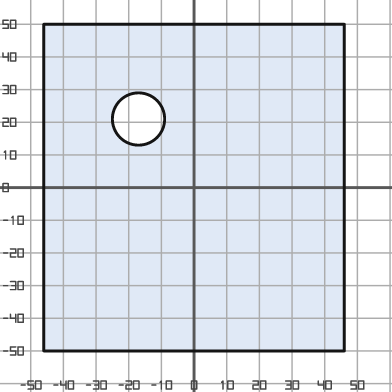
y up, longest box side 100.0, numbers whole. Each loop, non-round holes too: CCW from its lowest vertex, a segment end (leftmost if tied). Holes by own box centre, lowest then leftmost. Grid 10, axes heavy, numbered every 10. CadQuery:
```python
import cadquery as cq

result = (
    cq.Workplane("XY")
    .moveTo(-46.0, -50.0)
    .lineTo(46.0, -50.0)
    .lineTo(46.0, 50.0)
    .lineTo(-46.0, 50.0)
    .close()
    .moveTo(-17.0, 21.0)
    .circle(8.0)
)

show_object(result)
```